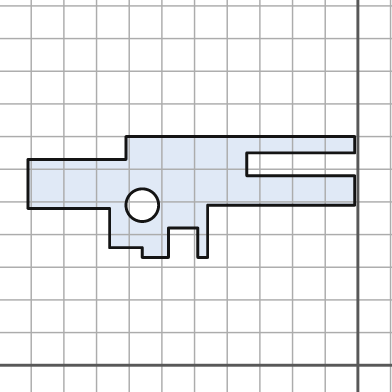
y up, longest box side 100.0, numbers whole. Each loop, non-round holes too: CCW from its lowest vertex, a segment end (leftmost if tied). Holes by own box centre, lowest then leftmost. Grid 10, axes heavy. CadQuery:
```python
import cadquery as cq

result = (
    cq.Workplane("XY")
    .moveTo(-66.0, 33.0)
    .lineTo(-58.0, 33.0)
    .lineTo(-58.0, 42.0)
    .lineTo(-49.0, 42.0)
    .lineTo(-49.0, 33.0)
    .lineTo(-46.0, 33.0)
    .lineTo(-46.0, 49.0)
    .lineTo(-1.0, 49.0)
    .lineTo(-1.0, 58.0)
    .lineTo(-34.0, 58.0)
    .lineTo(-34.0, 65.0)
    .lineTo(-1.0, 65.0)
    .lineTo(-1.0, 70.0)
    .lineTo(-71.0, 70.0)
    .lineTo(-71.0, 63.0)
    .lineTo(-101.0, 63.0)
    .lineTo(-101.0, 48.0)
    .lineTo(-76.0, 48.0)
    .lineTo(-76.0, 36.0)
    .lineTo(-66.0, 36.0)
    .close()
    .moveTo(-66.0, 49.0)
    .circle(5.0)
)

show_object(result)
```